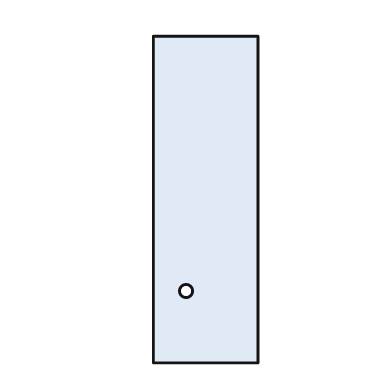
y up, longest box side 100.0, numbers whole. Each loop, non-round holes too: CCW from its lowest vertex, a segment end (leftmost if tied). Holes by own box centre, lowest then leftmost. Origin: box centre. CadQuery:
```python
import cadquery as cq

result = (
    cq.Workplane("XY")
    .moveTo(-16.0, -50.0)
    .lineTo(16.0, -50.0)
    .lineTo(16.0, 50.0)
    .lineTo(-16.0, 50.0)
    .close()
    .moveTo(-6.0, -28.0)
    .circle(2.0)
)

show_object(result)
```